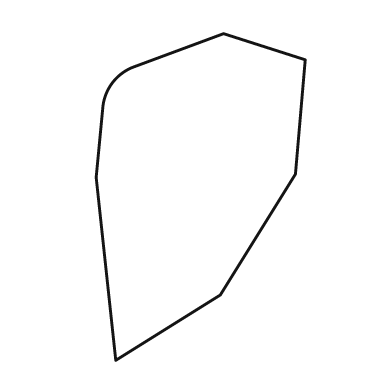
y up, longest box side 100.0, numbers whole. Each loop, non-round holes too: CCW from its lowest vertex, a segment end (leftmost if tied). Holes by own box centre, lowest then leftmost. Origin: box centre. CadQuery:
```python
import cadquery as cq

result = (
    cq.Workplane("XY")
    .moveTo(-26.0, -50.0)
    .lineTo(6.0, -30.0)
    .lineTo(29.0, 7.0)
    .lineTo(32.0, 42.0)
    .lineTo(7.0, 50.0)
    .lineTo(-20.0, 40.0)
    .threePointArc((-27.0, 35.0), (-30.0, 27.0))
    .lineTo(-32.0, 6.0)
    .close()
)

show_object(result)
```